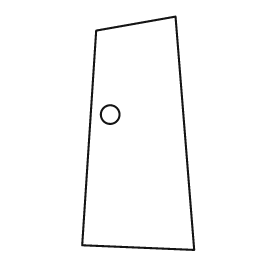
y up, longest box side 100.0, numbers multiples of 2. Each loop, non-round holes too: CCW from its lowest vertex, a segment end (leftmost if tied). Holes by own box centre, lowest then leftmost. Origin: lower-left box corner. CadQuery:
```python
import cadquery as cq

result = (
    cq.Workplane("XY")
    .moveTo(48.0, 0.0)
    .lineTo(40.0, 100.0)
    .lineTo(6.0, 94.0)
    .lineTo(0.0, 2.0)
    .close()
    .moveTo(12.0, 58.0)
    .circle(4.0)
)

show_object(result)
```